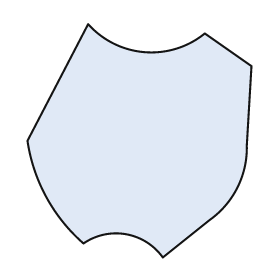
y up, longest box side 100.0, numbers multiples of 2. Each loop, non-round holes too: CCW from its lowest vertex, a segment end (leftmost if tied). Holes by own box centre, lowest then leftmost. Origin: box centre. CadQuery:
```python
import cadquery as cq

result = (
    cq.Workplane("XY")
    .moveTo(10.0, -50.0)
    .lineTo(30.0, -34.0)
    .threePointArc((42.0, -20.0), (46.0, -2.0))
    .lineTo(48.0, 32.0)
    .lineTo(28.0, 46.0)
    .threePointArc((2.0, 38.0), (-22.0, 50.0))
    .lineTo(-48.0, 0.0)
    .threePointArc((-40.0, -24.0), (-24.0, -44.0))
    .threePointArc((-6.0, -40.0), (10.0, -50.0))
    .close()
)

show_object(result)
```